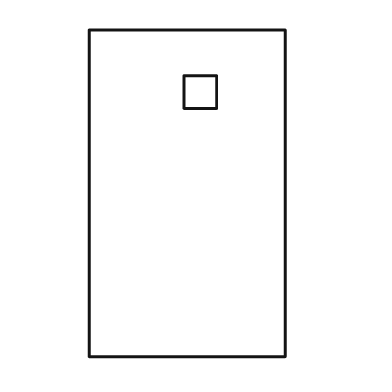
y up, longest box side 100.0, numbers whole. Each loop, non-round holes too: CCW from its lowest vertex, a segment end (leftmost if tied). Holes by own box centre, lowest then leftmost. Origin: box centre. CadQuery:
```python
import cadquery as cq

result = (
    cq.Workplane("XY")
    .moveTo(-30.0, -50.0)
    .lineTo(30.0, -50.0)
    .lineTo(30.0, 50.0)
    .lineTo(-30.0, 50.0)
    .close()
    .moveTo(-1.0, 26.0)
    .lineTo(9.0, 26.0)
    .lineTo(9.0, 36.0)
    .lineTo(-1.0, 36.0)
    .close()
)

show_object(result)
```